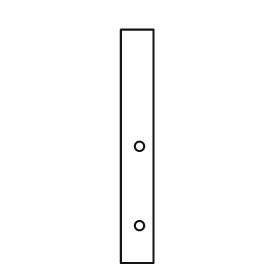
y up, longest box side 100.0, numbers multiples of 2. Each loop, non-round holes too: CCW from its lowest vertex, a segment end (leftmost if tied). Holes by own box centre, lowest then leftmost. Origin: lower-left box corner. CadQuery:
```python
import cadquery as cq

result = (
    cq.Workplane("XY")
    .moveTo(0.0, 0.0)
    .lineTo(14.0, 0.0)
    .lineTo(14.0, 100.0)
    .lineTo(0.0, 100.0)
    .close()
    .moveTo(8.0, 16.0)
    .circle(2.0)
    .moveTo(8.0, 50.0)
    .circle(2.0)
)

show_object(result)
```